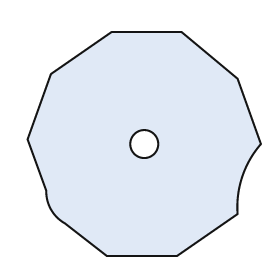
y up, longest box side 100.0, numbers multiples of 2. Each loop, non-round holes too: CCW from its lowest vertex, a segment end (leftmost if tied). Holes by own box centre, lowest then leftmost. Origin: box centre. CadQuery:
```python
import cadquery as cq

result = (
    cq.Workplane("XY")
    .moveTo(-16.0, -48.0)
    .lineTo(14.0, -48.0)
    .lineTo(40.0, -30.0)
    .threePointArc((42.0, -14.0), (50.0, 0.0))
    .lineTo(40.0, 28.0)
    .lineTo(16.0, 48.0)
    .lineTo(-14.0, 48.0)
    .lineTo(-40.0, 30.0)
    .lineTo(-50.0, 2.0)
    .lineTo(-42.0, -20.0)
    .threePointArc((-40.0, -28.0), (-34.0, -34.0))
    .close()
    .moveTo(0.0, 0.0)
    .circle(6.0)
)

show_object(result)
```